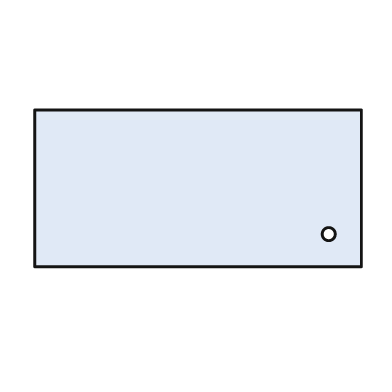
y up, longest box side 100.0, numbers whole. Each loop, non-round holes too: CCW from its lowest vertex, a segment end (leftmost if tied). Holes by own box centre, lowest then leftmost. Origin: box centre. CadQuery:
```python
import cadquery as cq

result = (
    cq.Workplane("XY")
    .moveTo(-50.0, -24.0)
    .lineTo(50.0, -24.0)
    .lineTo(50.0, 24.0)
    .lineTo(-50.0, 24.0)
    .close()
    .moveTo(40.0, -14.0)
    .circle(2.0)
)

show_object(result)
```